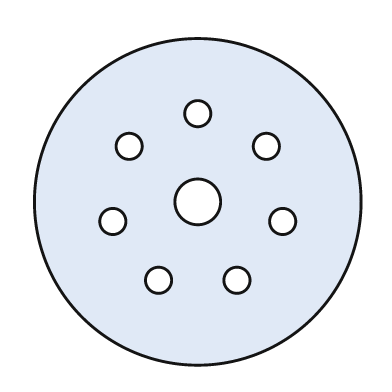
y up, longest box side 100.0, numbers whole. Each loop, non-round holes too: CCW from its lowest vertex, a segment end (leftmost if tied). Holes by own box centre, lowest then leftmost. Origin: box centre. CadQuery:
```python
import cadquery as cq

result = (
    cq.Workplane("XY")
    .moveTo(0.0, 0.0)
    .circle(50.0)
    .moveTo(-12.0, -24.0)
    .circle(4.0)
    .moveTo(12.0, -24.0)
    .circle(4.0)
    .moveTo(-26.0, -6.0)
    .circle(4.0)
    .moveTo(26.0, -6.0)
    .circle(4.0)
    .moveTo(0.0, 0.0)
    .circle(7.0)
    .moveTo(-21.0, 17.0)
    .circle(4.0)
    .moveTo(21.0, 17.0)
    .circle(4.0)
    .moveTo(0.0, 27.0)
    .circle(4.0)
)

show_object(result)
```